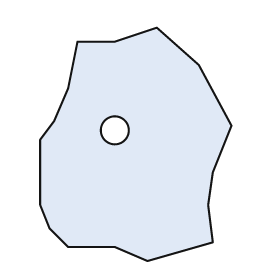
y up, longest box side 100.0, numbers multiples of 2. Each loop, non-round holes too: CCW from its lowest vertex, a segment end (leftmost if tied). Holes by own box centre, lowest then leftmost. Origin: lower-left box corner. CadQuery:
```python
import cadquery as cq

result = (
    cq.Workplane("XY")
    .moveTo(46.0, 0.0)
    .lineTo(74.0, 8.0)
    .lineTo(72.0, 24.0)
    .lineTo(74.0, 38.0)
    .lineTo(82.0, 58.0)
    .lineTo(68.0, 84.0)
    .lineTo(50.0, 100.0)
    .lineTo(32.0, 94.0)
    .lineTo(16.0, 94.0)
    .lineTo(12.0, 74.0)
    .lineTo(6.0, 60.0)
    .lineTo(0.0, 52.0)
    .lineTo(0.0, 24.0)
    .lineTo(4.0, 14.0)
    .lineTo(12.0, 6.0)
    .lineTo(32.0, 6.0)
    .close()
    .moveTo(32.0, 56.0)
    .circle(6.0)
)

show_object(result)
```